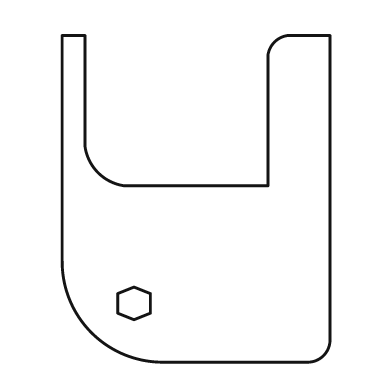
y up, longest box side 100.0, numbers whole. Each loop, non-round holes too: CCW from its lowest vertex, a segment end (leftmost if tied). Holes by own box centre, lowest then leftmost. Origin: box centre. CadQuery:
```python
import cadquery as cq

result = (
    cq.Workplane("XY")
    .moveTo(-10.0, -50.0)
    .lineTo(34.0, -50.0)
    .threePointArc((39.0, -48.0), (41.0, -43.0))
    .lineTo(41.0, 50.0)
    .lineTo(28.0, 50.0)
    .threePointArc((24.0, 48.0), (22.0, 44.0))
    .lineTo(22.0, 4.0)
    .lineTo(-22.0, 4.0)
    .threePointArc((-30.0, 8.0), (-34.0, 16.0))
    .lineTo(-34.0, 50.0)
    .lineTo(-41.0, 50.0)
    .lineTo(-41.0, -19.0)
    .threePointArc((-32.0, -41.0), (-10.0, -50.0))
    .close()
    .moveTo(-19.0, -37.0)
    .lineTo(-14.0, -35.0)
    .lineTo(-14.0, -29.0)
    .lineTo(-19.0, -27.0)
    .lineTo(-24.0, -29.0)
    .lineTo(-24.0, -35.0)
    .close()
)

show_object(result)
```